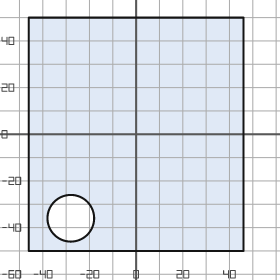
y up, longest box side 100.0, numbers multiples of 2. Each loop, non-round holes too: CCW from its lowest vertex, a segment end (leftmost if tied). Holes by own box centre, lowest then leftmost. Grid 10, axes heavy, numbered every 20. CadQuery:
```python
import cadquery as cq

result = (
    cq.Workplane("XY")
    .moveTo(-46.0, -50.0)
    .lineTo(46.0, -50.0)
    .lineTo(46.0, 50.0)
    .lineTo(-46.0, 50.0)
    .close()
    .moveTo(-28.0, -36.0)
    .circle(10.0)
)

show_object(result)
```